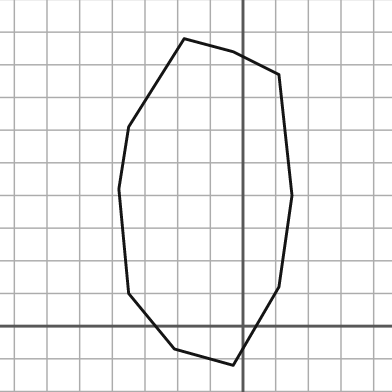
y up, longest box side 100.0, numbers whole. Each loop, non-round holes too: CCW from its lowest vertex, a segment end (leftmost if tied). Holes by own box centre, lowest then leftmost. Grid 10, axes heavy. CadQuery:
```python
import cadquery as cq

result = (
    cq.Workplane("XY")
    .moveTo(-3.0, -12.0)
    .lineTo(11.0, 12.0)
    .lineTo(15.0, 40.0)
    .lineTo(11.0, 77.0)
    .lineTo(-3.0, 84.0)
    .lineTo(-18.0, 88.0)
    .lineTo(-35.0, 61.0)
    .lineTo(-38.0, 42.0)
    .lineTo(-35.0, 10.0)
    .lineTo(-21.0, -7.0)
    .close()
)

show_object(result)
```